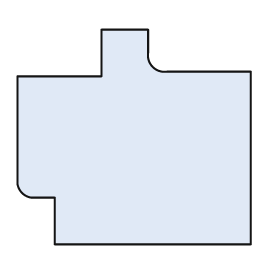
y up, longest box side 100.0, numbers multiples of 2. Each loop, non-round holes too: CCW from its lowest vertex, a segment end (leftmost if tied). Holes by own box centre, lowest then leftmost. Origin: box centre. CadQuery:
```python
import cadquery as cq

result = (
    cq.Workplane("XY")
    .moveTo(-34.0, -46.0)
    .lineTo(50.0, -46.0)
    .lineTo(50.0, 28.0)
    .lineTo(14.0, 28.0)
    .threePointArc((8.0, 30.0), (6.0, 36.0))
    .lineTo(6.0, 46.0)
    .lineTo(-14.0, 46.0)
    .lineTo(-14.0, 26.0)
    .lineTo(-50.0, 26.0)
    .lineTo(-50.0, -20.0)
    .threePointArc((-48.0, -24.0), (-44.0, -26.0))
    .lineTo(-34.0, -26.0)
    .close()
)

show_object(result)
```